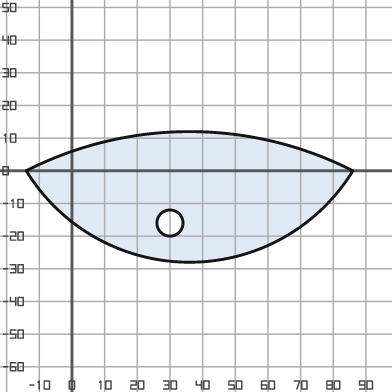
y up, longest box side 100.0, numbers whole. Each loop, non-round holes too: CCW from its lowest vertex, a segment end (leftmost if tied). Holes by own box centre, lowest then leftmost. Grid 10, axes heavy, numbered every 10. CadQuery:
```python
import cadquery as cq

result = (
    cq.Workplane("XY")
    .moveTo(-14.0, 0.0)
    .threePointArc((36.0, -28.0), (86.0, 0.0))
    .threePointArc((36.0, 12.0), (-14.0, 0.0))
    .close()
    .moveTo(30.0, -16.0)
    .circle(4.0)
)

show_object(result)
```